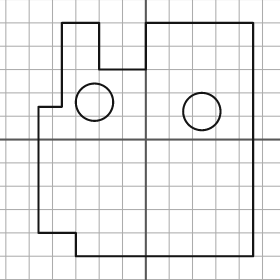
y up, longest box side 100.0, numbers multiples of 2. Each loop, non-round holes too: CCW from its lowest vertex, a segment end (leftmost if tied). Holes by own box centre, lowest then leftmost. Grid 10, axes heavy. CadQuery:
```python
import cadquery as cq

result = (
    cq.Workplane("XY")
    .moveTo(-30.0, -50.0)
    .lineTo(46.0, -50.0)
    .lineTo(46.0, 50.0)
    .lineTo(0.0, 50.0)
    .lineTo(0.0, 30.0)
    .lineTo(-20.0, 30.0)
    .lineTo(-20.0, 50.0)
    .lineTo(-36.0, 50.0)
    .lineTo(-36.0, 14.0)
    .lineTo(-46.0, 14.0)
    .lineTo(-46.0, -40.0)
    .lineTo(-30.0, -40.0)
    .close()
    .moveTo(24.0, 12.0)
    .circle(8.0)
    .moveTo(-22.0, 16.0)
    .circle(8.0)
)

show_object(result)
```